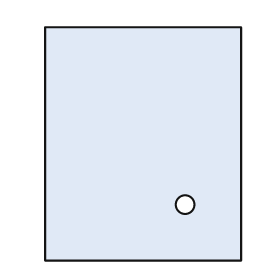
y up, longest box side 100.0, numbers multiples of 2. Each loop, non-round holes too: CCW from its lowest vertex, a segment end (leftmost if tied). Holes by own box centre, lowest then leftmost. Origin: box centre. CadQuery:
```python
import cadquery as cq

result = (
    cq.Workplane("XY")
    .moveTo(-42.0, -50.0)
    .lineTo(42.0, -50.0)
    .lineTo(42.0, 50.0)
    .lineTo(-42.0, 50.0)
    .close()
    .moveTo(18.0, -26.0)
    .circle(4.0)
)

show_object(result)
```